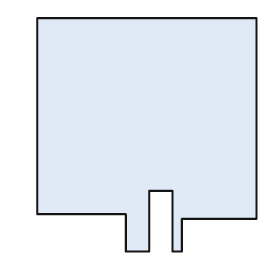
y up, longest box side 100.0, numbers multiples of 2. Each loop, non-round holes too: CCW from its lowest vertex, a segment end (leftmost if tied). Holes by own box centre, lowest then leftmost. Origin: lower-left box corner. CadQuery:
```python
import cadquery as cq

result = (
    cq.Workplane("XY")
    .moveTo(38.0, 0.0)
    .lineTo(48.0, 0.0)
    .lineTo(48.0, 26.0)
    .lineTo(58.0, 26.0)
    .lineTo(58.0, 0.0)
    .lineTo(62.0, 0.0)
    .lineTo(62.0, 14.0)
    .lineTo(94.0, 14.0)
    .lineTo(94.0, 100.0)
    .lineTo(0.0, 100.0)
    .lineTo(0.0, 16.0)
    .lineTo(38.0, 16.0)
    .close()
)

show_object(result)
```